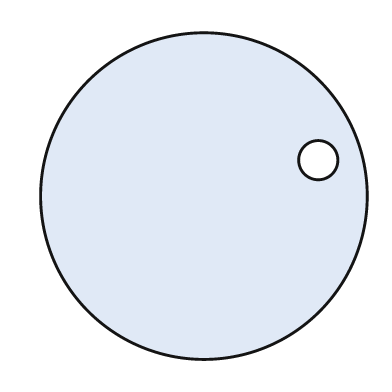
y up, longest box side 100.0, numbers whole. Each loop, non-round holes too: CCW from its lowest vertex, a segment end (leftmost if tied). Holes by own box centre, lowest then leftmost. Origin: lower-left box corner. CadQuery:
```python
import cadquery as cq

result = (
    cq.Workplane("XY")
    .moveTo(50.0, 50.0)
    .circle(50.0)
    .moveTo(85.0, 61.0)
    .circle(6.0)
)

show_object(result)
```